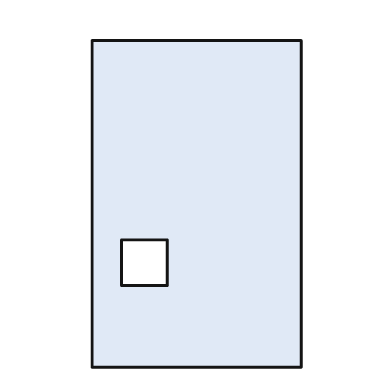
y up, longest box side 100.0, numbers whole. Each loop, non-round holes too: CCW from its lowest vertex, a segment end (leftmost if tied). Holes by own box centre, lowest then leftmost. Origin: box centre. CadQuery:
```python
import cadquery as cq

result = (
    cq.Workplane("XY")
    .moveTo(-32.0, -50.0)
    .lineTo(32.0, -50.0)
    .lineTo(32.0, 50.0)
    .lineTo(-32.0, 50.0)
    .close()
    .moveTo(-23.0, -25.0)
    .lineTo(-9.0, -25.0)
    .lineTo(-9.0, -11.0)
    .lineTo(-23.0, -11.0)
    .close()
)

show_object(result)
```